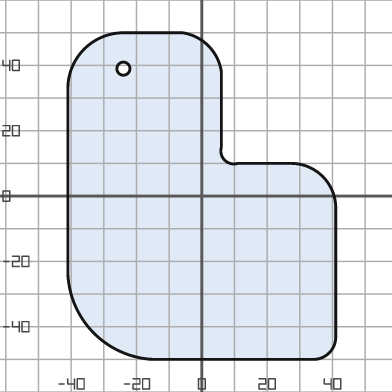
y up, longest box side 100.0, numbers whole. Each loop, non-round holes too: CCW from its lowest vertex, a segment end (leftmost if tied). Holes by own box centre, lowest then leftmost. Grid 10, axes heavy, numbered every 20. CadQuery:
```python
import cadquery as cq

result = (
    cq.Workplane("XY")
    .moveTo(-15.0, -50.0)
    .lineTo(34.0, -50.0)
    .threePointArc((39.0, -48.0), (41.0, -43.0))
    .lineTo(41.0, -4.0)
    .threePointArc((37.0, 6.0), (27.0, 10.0))
    .lineTo(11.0, 10.0)
    .threePointArc((7.0, 11.0), (6.0, 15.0))
    .lineTo(6.0, 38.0)
    .threePointArc((2.0, 46.0), (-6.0, 50.0))
    .lineTo(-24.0, 50.0)
    .threePointArc((-36.0, 45.0), (-41.0, 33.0))
    .lineTo(-41.0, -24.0)
    .threePointArc((-33.0, -42.0), (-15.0, -50.0))
    .close()
    .moveTo(-24.0, 39.0)
    .circle(2.0)
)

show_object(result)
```